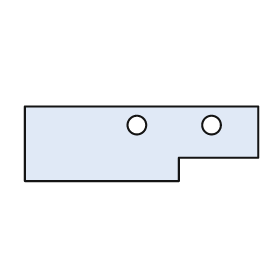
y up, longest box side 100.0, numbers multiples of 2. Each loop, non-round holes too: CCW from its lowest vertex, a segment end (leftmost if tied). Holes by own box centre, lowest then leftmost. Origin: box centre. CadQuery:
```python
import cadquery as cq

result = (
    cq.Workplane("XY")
    .moveTo(-50.0, -16.0)
    .lineTo(16.0, -16.0)
    .lineTo(16.0, -6.0)
    .lineTo(50.0, -6.0)
    .lineTo(50.0, 16.0)
    .lineTo(-50.0, 16.0)
    .close()
    .moveTo(-2.0, 8.0)
    .circle(4.0)
    .moveTo(30.0, 8.0)
    .circle(4.0)
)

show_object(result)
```